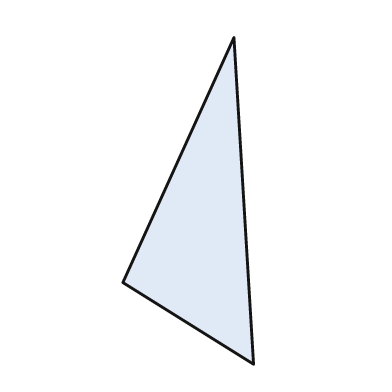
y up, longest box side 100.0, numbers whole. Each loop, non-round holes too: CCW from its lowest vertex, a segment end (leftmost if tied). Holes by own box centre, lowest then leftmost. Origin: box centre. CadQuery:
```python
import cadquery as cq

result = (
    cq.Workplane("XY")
    .moveTo(20.0, -50.0)
    .lineTo(14.0, 50.0)
    .lineTo(-20.0, -25.0)
    .close()
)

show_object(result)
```